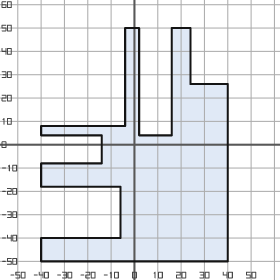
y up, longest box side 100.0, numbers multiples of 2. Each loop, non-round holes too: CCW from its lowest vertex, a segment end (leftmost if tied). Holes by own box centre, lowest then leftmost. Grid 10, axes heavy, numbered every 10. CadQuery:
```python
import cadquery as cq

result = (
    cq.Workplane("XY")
    .moveTo(-40.0, -50.0)
    .lineTo(40.0, -50.0)
    .lineTo(40.0, 26.0)
    .lineTo(24.0, 26.0)
    .lineTo(24.0, 50.0)
    .lineTo(16.0, 50.0)
    .lineTo(16.0, 4.0)
    .lineTo(2.0, 4.0)
    .lineTo(2.0, 50.0)
    .lineTo(-4.0, 50.0)
    .lineTo(-4.0, 8.0)
    .lineTo(-40.0, 8.0)
    .lineTo(-40.0, 4.0)
    .lineTo(-14.0, 4.0)
    .lineTo(-14.0, -8.0)
    .lineTo(-40.0, -8.0)
    .lineTo(-40.0, -18.0)
    .lineTo(-6.0, -18.0)
    .lineTo(-6.0, -40.0)
    .lineTo(-40.0, -40.0)
    .close()
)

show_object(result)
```